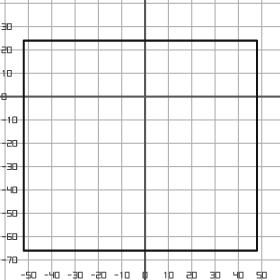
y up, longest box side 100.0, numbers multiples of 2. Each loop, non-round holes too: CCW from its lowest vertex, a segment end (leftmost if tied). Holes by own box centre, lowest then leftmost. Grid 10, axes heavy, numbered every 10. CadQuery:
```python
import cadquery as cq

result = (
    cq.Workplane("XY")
    .moveTo(-52.0, -66.0)
    .lineTo(48.0, -66.0)
    .lineTo(48.0, 24.0)
    .lineTo(-52.0, 24.0)
    .close()
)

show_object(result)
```